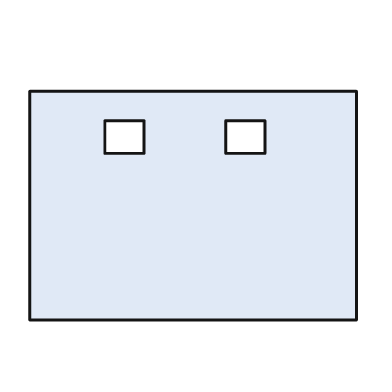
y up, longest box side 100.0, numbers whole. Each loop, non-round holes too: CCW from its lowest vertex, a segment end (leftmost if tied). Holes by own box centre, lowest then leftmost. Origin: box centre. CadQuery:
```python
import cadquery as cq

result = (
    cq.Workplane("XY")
    .moveTo(-50.0, -35.0)
    .lineTo(50.0, -35.0)
    .lineTo(50.0, 35.0)
    .lineTo(-50.0, 35.0)
    .close()
    .moveTo(-27.0, 16.0)
    .lineTo(-15.0, 16.0)
    .lineTo(-15.0, 26.0)
    .lineTo(-27.0, 26.0)
    .close()
    .moveTo(10.0, 16.0)
    .lineTo(22.0, 16.0)
    .lineTo(22.0, 26.0)
    .lineTo(10.0, 26.0)
    .close()
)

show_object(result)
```